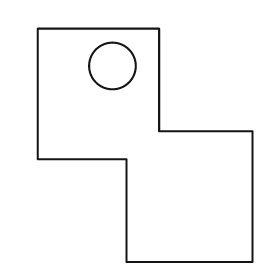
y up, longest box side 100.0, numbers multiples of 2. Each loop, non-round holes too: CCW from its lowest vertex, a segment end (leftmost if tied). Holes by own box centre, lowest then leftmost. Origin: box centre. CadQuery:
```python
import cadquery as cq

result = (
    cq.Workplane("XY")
    .moveTo(-8.0, -50.0)
    .lineTo(46.0, -50.0)
    .lineTo(46.0, 6.0)
    .lineTo(6.0, 6.0)
    .lineTo(6.0, 50.0)
    .lineTo(-46.0, 50.0)
    .lineTo(-46.0, -6.0)
    .lineTo(-8.0, -6.0)
    .close()
    .moveTo(-14.0, 34.0)
    .circle(10.0)
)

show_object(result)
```